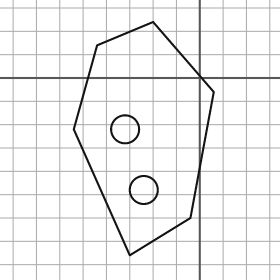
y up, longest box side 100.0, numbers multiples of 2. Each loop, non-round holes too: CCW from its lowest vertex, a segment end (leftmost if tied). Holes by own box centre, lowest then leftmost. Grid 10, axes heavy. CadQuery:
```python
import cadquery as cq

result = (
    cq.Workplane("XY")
    .moveTo(-30.0, -76.0)
    .lineTo(-4.0, -60.0)
    .lineTo(6.0, -6.0)
    .lineTo(-20.0, 24.0)
    .lineTo(-44.0, 14.0)
    .lineTo(-54.0, -22.0)
    .close()
    .moveTo(-24.0, -48.0)
    .circle(6.0)
    .moveTo(-32.0, -22.0)
    .circle(6.0)
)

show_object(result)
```